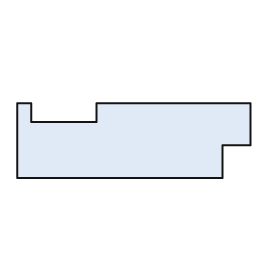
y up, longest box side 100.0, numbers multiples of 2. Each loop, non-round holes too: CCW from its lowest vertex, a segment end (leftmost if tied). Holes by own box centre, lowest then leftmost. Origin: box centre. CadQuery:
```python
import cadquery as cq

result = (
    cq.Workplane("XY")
    .moveTo(-50.0, -16.0)
    .lineTo(38.0, -16.0)
    .lineTo(38.0, -2.0)
    .lineTo(50.0, -2.0)
    .lineTo(50.0, 16.0)
    .lineTo(-16.0, 16.0)
    .lineTo(-16.0, 8.0)
    .lineTo(-44.0, 8.0)
    .lineTo(-44.0, 16.0)
    .lineTo(-50.0, 16.0)
    .close()
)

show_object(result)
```